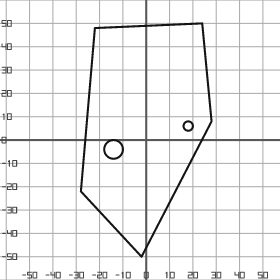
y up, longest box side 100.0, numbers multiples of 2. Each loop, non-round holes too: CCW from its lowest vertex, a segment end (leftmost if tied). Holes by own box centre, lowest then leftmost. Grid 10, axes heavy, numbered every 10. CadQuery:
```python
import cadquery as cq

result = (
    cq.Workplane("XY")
    .moveTo(-2.0, -50.0)
    .lineTo(28.0, 8.0)
    .lineTo(24.0, 50.0)
    .lineTo(-22.0, 48.0)
    .lineTo(-28.0, -22.0)
    .close()
    .moveTo(-14.0, -4.0)
    .circle(4.0)
    .moveTo(18.0, 6.0)
    .circle(2.0)
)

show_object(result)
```